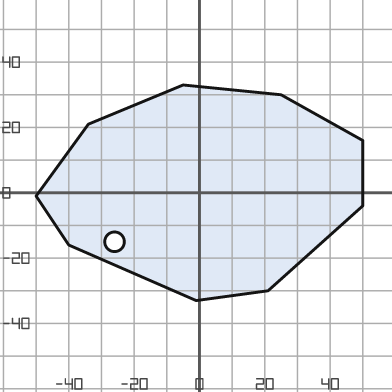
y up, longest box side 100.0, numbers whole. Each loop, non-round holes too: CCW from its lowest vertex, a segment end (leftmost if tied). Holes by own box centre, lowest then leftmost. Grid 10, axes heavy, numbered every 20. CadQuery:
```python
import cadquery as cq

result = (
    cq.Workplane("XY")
    .moveTo(-1.0, -33.0)
    .lineTo(21.0, -30.0)
    .lineTo(50.0, -4.0)
    .lineTo(50.0, 16.0)
    .lineTo(25.0, 30.0)
    .lineTo(-5.0, 33.0)
    .lineTo(-34.0, 21.0)
    .lineTo(-50.0, -1.0)
    .lineTo(-40.0, -16.0)
    .close()
    .moveTo(-26.0, -15.0)
    .circle(3.0)
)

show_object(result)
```